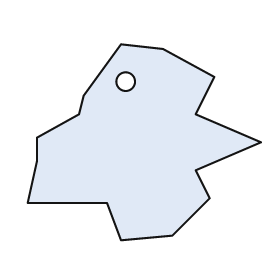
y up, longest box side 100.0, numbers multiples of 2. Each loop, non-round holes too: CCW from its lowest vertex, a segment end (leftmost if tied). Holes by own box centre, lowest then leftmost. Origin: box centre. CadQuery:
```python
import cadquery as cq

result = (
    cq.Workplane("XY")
    .moveTo(-10.0, -42.0)
    .lineTo(12.0, -40.0)
    .lineTo(28.0, -24.0)
    .lineTo(22.0, -12.0)
    .lineTo(50.0, 0.0)
    .lineTo(22.0, 12.0)
    .lineTo(30.0, 28.0)
    .lineTo(8.0, 40.0)
    .lineTo(-10.0, 42.0)
    .lineTo(-26.0, 20.0)
    .lineTo(-28.0, 12.0)
    .lineTo(-46.0, 2.0)
    .lineTo(-46.0, -8.0)
    .lineTo(-50.0, -26.0)
    .lineTo(-16.0, -26.0)
    .close()
    .moveTo(-8.0, 26.0)
    .circle(4.0)
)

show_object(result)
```